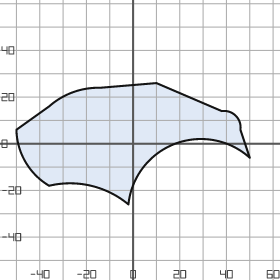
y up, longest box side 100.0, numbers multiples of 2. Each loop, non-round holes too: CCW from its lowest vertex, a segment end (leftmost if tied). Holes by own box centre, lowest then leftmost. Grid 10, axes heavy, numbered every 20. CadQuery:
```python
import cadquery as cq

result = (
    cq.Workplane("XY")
    .moveTo(-2.0, -26.0)
    .threePointArc((18.0, 0.0), (50.0, -6.0))
    .lineTo(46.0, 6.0)
    .threePointArc((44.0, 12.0), (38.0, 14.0))
    .lineTo(10.0, 26.0)
    .lineTo(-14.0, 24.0)
    .threePointArc((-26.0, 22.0), (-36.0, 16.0))
    .lineTo(-50.0, 6.0)
    .threePointArc((-46.0, -8.0), (-36.0, -18.0))
    .threePointArc((-18.0, -18.0), (-2.0, -26.0))
    .close()
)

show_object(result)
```